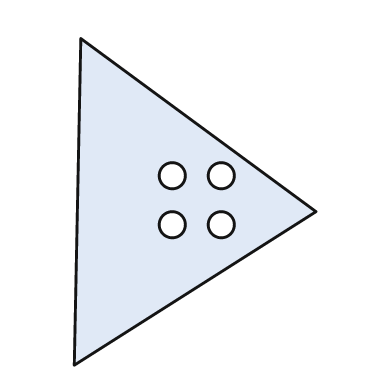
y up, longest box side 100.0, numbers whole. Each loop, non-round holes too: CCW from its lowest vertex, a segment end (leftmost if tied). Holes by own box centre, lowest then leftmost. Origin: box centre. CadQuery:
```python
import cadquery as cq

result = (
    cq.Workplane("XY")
    .moveTo(-37.0, -50.0)
    .lineTo(37.0, -3.0)
    .lineTo(-35.0, 50.0)
    .close()
    .moveTo(-7.0, -7.0)
    .circle(4.0)
    .moveTo(8.0, -7.0)
    .circle(4.0)
    .moveTo(-7.0, 8.0)
    .circle(4.0)
    .moveTo(8.0, 8.0)
    .circle(4.0)
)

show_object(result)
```